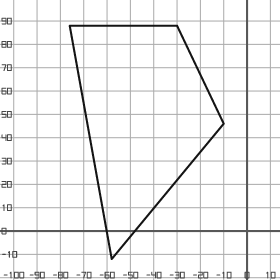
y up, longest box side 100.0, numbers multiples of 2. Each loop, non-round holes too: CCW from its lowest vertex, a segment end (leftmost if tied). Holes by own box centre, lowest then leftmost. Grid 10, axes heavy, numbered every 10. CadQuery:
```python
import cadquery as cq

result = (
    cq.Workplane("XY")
    .moveTo(-58.0, -12.0)
    .lineTo(-10.0, 46.0)
    .lineTo(-30.0, 88.0)
    .lineTo(-76.0, 88.0)
    .close()
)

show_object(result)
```